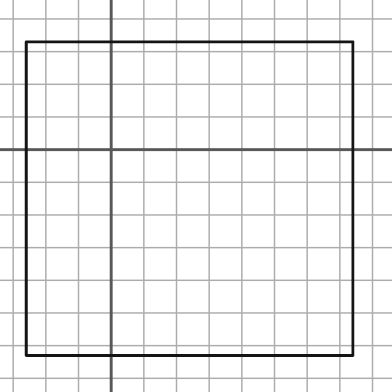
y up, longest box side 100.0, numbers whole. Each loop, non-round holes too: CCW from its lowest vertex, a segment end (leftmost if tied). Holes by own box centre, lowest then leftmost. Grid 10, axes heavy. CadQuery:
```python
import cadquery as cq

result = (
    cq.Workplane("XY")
    .moveTo(-26.0, -63.0)
    .lineTo(74.0, -63.0)
    .lineTo(74.0, 33.0)
    .lineTo(-26.0, 33.0)
    .close()
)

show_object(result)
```